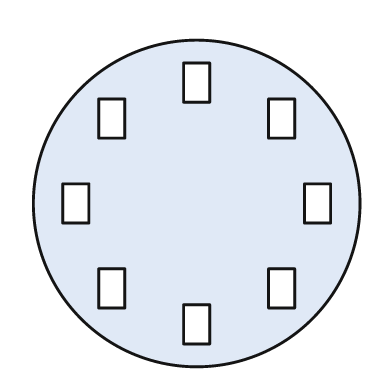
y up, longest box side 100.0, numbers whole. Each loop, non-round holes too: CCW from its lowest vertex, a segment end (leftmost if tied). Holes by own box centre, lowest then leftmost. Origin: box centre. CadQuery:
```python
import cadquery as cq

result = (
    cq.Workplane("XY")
    .moveTo(0.0, 0.0)
    .circle(50.0)
    .moveTo(-4.0, -43.0)
    .lineTo(4.0, -43.0)
    .lineTo(4.0, -31.0)
    .lineTo(-4.0, -31.0)
    .close()
    .moveTo(-30.0, -32.0)
    .lineTo(-22.0, -32.0)
    .lineTo(-22.0, -20.0)
    .lineTo(-30.0, -20.0)
    .close()
    .moveTo(22.0, -32.0)
    .lineTo(30.0, -32.0)
    .lineTo(30.0, -20.0)
    .lineTo(22.0, -20.0)
    .close()
    .moveTo(-41.0, -6.0)
    .lineTo(-33.0, -6.0)
    .lineTo(-33.0, 6.0)
    .lineTo(-41.0, 6.0)
    .close()
    .moveTo(33.0, -6.0)
    .lineTo(41.0, -6.0)
    .lineTo(41.0, 6.0)
    .lineTo(33.0, 6.0)
    .close()
    .moveTo(-30.0, 20.0)
    .lineTo(-22.0, 20.0)
    .lineTo(-22.0, 32.0)
    .lineTo(-30.0, 32.0)
    .close()
    .moveTo(22.0, 20.0)
    .lineTo(30.0, 20.0)
    .lineTo(30.0, 32.0)
    .lineTo(22.0, 32.0)
    .close()
    .moveTo(-4.0, 31.0)
    .lineTo(4.0, 31.0)
    .lineTo(4.0, 43.0)
    .lineTo(-4.0, 43.0)
    .close()
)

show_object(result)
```